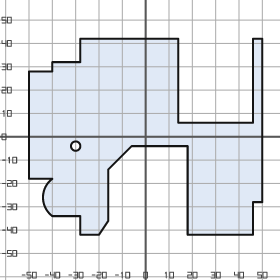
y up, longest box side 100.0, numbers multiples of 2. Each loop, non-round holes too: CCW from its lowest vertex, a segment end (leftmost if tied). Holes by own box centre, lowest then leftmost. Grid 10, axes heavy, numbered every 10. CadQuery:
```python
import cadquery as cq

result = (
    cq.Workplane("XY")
    .moveTo(-28.0, -42.0)
    .lineTo(-20.0, -42.0)
    .lineTo(-16.0, -36.0)
    .lineTo(-16.0, -14.0)
    .lineTo(-6.0, -4.0)
    .lineTo(18.0, -4.0)
    .lineTo(18.0, -42.0)
    .lineTo(46.0, -42.0)
    .lineTo(46.0, -28.0)
    .lineTo(50.0, -28.0)
    .lineTo(50.0, 42.0)
    .lineTo(46.0, 42.0)
    .lineTo(46.0, 6.0)
    .lineTo(14.0, 6.0)
    .lineTo(14.0, 42.0)
    .lineTo(-28.0, 42.0)
    .lineTo(-28.0, 32.0)
    .lineTo(-40.0, 32.0)
    .lineTo(-40.0, 28.0)
    .lineTo(-50.0, 28.0)
    .lineTo(-50.0, -18.0)
    .lineTo(-40.0, -18.0)
    .threePointArc((-44.0, -26.0), (-40.0, -34.0))
    .lineTo(-28.0, -34.0)
    .close()
    .moveTo(-30.0, -4.0)
    .circle(2.0)
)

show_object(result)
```